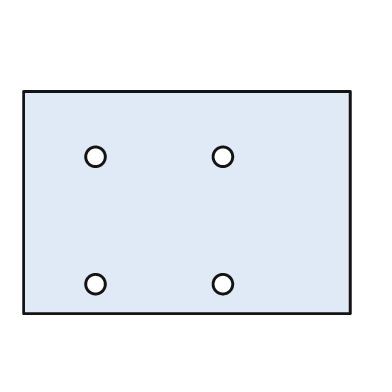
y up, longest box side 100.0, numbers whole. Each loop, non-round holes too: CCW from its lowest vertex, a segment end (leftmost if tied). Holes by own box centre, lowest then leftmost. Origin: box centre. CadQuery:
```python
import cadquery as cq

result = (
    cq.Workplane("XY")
    .moveTo(-50.0, -34.0)
    .lineTo(50.0, -34.0)
    .lineTo(50.0, 34.0)
    .lineTo(-50.0, 34.0)
    .close()
    .moveTo(-28.0, -25.0)
    .circle(3.0)
    .moveTo(11.0, -25.0)
    .circle(3.0)
    .moveTo(-28.0, 14.0)
    .circle(3.0)
    .moveTo(11.0, 14.0)
    .circle(3.0)
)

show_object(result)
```